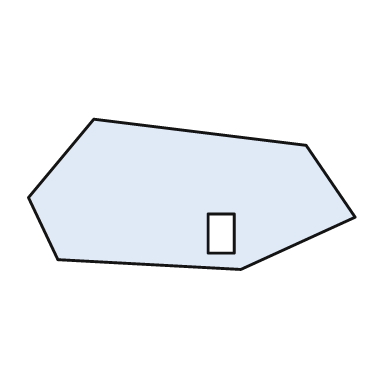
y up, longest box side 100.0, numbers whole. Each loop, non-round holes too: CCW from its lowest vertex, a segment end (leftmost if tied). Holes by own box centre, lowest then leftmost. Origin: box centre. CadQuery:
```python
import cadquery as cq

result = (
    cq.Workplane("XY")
    .moveTo(15.0, -23.0)
    .lineTo(50.0, -7.0)
    .lineTo(35.0, 15.0)
    .lineTo(-30.0, 23.0)
    .lineTo(-50.0, -1.0)
    .lineTo(-41.0, -20.0)
    .close()
    .moveTo(5.0, -18.0)
    .lineTo(13.0, -18.0)
    .lineTo(13.0, -6.0)
    .lineTo(5.0, -6.0)
    .close()
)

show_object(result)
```